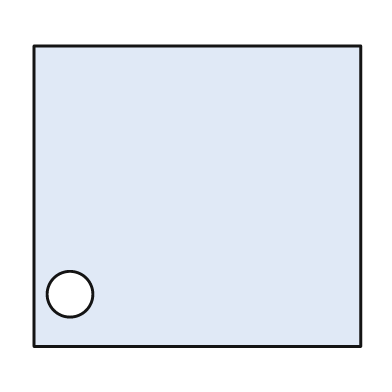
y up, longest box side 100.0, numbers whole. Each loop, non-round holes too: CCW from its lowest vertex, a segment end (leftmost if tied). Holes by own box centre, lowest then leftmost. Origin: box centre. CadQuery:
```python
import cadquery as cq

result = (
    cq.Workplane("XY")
    .moveTo(-50.0, -46.0)
    .lineTo(50.0, -46.0)
    .lineTo(50.0, 46.0)
    .lineTo(-50.0, 46.0)
    .close()
    .moveTo(-39.0, -30.0)
    .circle(7.0)
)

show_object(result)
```